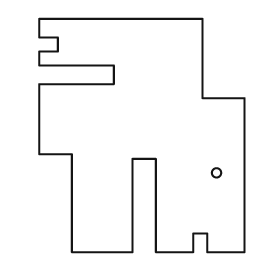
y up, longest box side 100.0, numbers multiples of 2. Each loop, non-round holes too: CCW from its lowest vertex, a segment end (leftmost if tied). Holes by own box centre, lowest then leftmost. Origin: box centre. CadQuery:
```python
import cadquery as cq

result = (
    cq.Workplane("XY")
    .moveTo(-30.0, -50.0)
    .lineTo(-4.0, -50.0)
    .lineTo(-4.0, -10.0)
    .lineTo(6.0, -10.0)
    .lineTo(6.0, -50.0)
    .lineTo(22.0, -50.0)
    .lineTo(22.0, -42.0)
    .lineTo(28.0, -42.0)
    .lineTo(28.0, -50.0)
    .lineTo(44.0, -50.0)
    .lineTo(44.0, 16.0)
    .lineTo(26.0, 16.0)
    .lineTo(26.0, 50.0)
    .lineTo(-44.0, 50.0)
    .lineTo(-44.0, 42.0)
    .lineTo(-36.0, 42.0)
    .lineTo(-36.0, 36.0)
    .lineTo(-44.0, 36.0)
    .lineTo(-44.0, 30.0)
    .lineTo(-12.0, 30.0)
    .lineTo(-12.0, 22.0)
    .lineTo(-44.0, 22.0)
    .lineTo(-44.0, -8.0)
    .lineTo(-30.0, -8.0)
    .close()
    .moveTo(32.0, -16.0)
    .circle(2.0)
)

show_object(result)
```